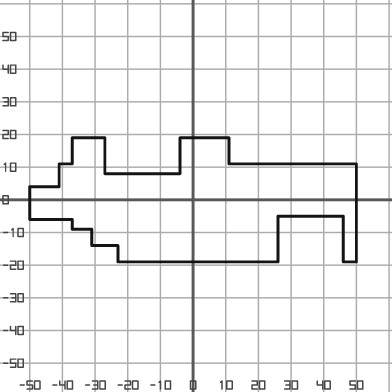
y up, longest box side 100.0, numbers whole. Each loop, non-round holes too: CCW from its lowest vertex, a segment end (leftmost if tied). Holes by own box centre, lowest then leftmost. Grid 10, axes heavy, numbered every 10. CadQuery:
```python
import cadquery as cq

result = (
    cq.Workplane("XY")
    .moveTo(-23.0, -19.0)
    .lineTo(26.0, -19.0)
    .lineTo(26.0, -5.0)
    .lineTo(46.0, -5.0)
    .lineTo(46.0, -19.0)
    .lineTo(50.0, -19.0)
    .lineTo(50.0, 11.0)
    .lineTo(11.0, 11.0)
    .lineTo(11.0, 19.0)
    .lineTo(-4.0, 19.0)
    .lineTo(-4.0, 8.0)
    .lineTo(-27.0, 8.0)
    .lineTo(-27.0, 19.0)
    .lineTo(-37.0, 19.0)
    .lineTo(-37.0, 11.0)
    .lineTo(-41.0, 11.0)
    .lineTo(-41.0, 4.0)
    .lineTo(-50.0, 4.0)
    .lineTo(-50.0, -6.0)
    .lineTo(-37.0, -6.0)
    .lineTo(-37.0, -9.0)
    .lineTo(-31.0, -9.0)
    .lineTo(-31.0, -14.0)
    .lineTo(-23.0, -14.0)
    .close()
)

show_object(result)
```